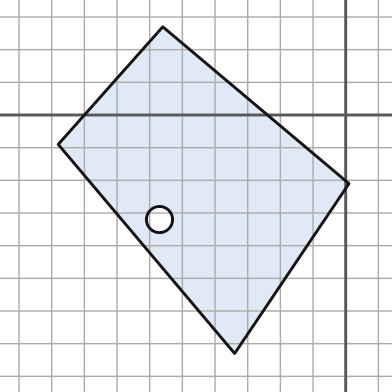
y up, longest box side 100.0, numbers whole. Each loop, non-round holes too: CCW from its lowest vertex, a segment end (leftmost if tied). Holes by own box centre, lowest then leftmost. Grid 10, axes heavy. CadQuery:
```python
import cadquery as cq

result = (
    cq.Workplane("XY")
    .moveTo(-34.0, -73.0)
    .lineTo(1.0, -21.0)
    .lineTo(-56.0, 27.0)
    .lineTo(-88.0, -9.0)
    .close()
    .moveTo(-57.0, -32.0)
    .circle(4.0)
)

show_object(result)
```